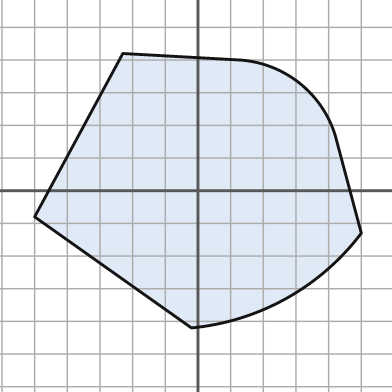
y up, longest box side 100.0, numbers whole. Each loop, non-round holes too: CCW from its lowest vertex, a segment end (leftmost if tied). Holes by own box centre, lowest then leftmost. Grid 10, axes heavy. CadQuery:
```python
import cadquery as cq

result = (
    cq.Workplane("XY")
    .moveTo(-2.0, -42.0)
    .threePointArc((27.0, -33.0), (50.0, -13.0))
    .lineTo(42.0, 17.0)
    .threePointArc((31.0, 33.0), (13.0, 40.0))
    .lineTo(-23.0, 42.0)
    .lineTo(-50.0, -8.0)
    .close()
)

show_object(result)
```